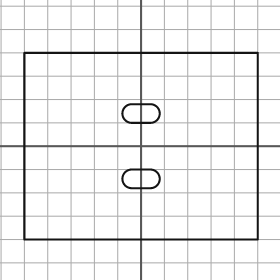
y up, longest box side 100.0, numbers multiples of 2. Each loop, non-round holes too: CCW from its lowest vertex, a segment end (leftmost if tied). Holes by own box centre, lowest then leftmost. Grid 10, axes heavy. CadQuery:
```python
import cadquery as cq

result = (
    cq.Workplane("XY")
    .moveTo(-50.0, -40.0)
    .lineTo(50.0, -40.0)
    .lineTo(50.0, 40.0)
    .lineTo(-50.0, 40.0)
    .close()
    .moveTo(-4.0, -18.0)
    .lineTo(4.0, -18.0)
    .threePointArc((8.0, -14.0), (4.0, -10.0))
    .lineTo(-4.0, -10.0)
    .threePointArc((-8.0, -14.0), (-4.0, -18.0))
    .close()
    .moveTo(-4.0, 10.0)
    .lineTo(4.0, 10.0)
    .threePointArc((8.0, 14.0), (4.0, 18.0))
    .lineTo(-4.0, 18.0)
    .threePointArc((-8.0, 14.0), (-4.0, 10.0))
    .close()
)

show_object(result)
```